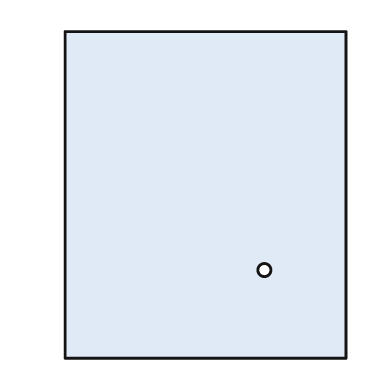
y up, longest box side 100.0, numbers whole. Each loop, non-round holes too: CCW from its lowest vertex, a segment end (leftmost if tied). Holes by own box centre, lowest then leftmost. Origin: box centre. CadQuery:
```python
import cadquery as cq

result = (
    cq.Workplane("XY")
    .moveTo(-43.0, -50.0)
    .lineTo(43.0, -50.0)
    .lineTo(43.0, 50.0)
    .lineTo(-43.0, 50.0)
    .close()
    .moveTo(18.0, -23.0)
    .circle(2.0)
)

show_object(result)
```